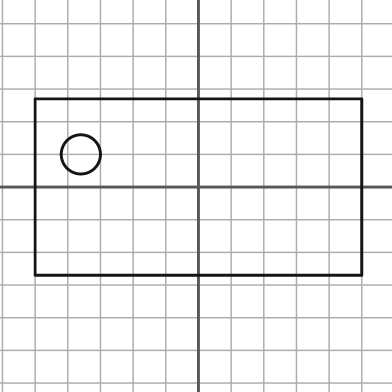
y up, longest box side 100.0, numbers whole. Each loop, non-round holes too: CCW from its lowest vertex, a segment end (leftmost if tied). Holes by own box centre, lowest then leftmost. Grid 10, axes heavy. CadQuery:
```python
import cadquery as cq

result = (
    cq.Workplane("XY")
    .moveTo(-50.0, -27.0)
    .lineTo(50.0, -27.0)
    .lineTo(50.0, 27.0)
    .lineTo(-50.0, 27.0)
    .close()
    .moveTo(-36.0, 10.0)
    .circle(6.0)
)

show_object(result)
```